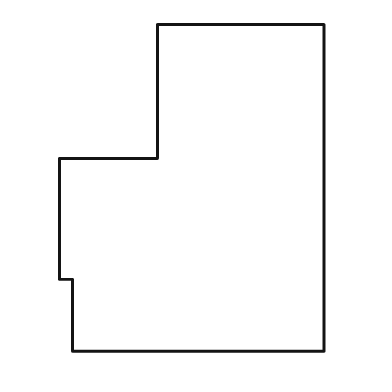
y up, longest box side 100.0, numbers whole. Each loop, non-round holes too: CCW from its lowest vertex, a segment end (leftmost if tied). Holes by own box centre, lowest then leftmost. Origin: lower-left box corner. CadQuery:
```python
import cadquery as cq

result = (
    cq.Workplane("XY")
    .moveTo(4.0, 0.0)
    .lineTo(81.0, 0.0)
    .lineTo(81.0, 100.0)
    .lineTo(30.0, 100.0)
    .lineTo(30.0, 59.0)
    .lineTo(0.0, 59.0)
    .lineTo(0.0, 22.0)
    .lineTo(4.0, 22.0)
    .close()
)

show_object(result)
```